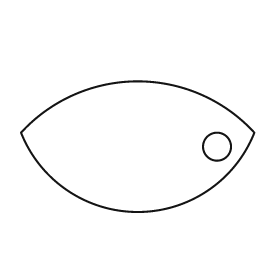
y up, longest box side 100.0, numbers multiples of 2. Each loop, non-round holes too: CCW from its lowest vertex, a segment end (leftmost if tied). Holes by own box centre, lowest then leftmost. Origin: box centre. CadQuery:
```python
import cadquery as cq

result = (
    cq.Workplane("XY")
    .moveTo(-50.0, 6.0)
    .threePointArc((0.0, -28.0), (50.0, 6.0))
    .threePointArc((0.0, 28.0), (-50.0, 6.0))
    .close()
    .moveTo(34.0, 0.0)
    .circle(6.0)
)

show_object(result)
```